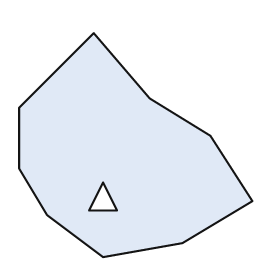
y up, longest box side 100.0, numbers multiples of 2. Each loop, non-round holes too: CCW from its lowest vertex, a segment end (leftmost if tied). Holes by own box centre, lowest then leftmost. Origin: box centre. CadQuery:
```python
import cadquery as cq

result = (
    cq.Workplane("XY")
    .moveTo(-14.0, -48.0)
    .lineTo(20.0, -42.0)
    .lineTo(50.0, -24.0)
    .lineTo(32.0, 4.0)
    .lineTo(6.0, 20.0)
    .lineTo(-18.0, 48.0)
    .lineTo(-50.0, 16.0)
    .lineTo(-50.0, -10.0)
    .lineTo(-38.0, -30.0)
    .close()
    .moveTo(-20.0, -28.0)
    .lineTo(-8.0, -28.0)
    .lineTo(-14.0, -16.0)
    .close()
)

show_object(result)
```